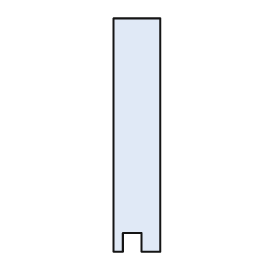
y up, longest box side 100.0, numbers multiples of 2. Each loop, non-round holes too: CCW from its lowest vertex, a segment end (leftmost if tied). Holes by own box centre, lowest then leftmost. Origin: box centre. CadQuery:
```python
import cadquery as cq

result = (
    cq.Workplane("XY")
    .moveTo(-10.0, -50.0)
    .lineTo(-6.0, -50.0)
    .lineTo(-6.0, -42.0)
    .lineTo(2.0, -42.0)
    .lineTo(2.0, -50.0)
    .lineTo(10.0, -50.0)
    .lineTo(10.0, 50.0)
    .lineTo(-10.0, 50.0)
    .close()
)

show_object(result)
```